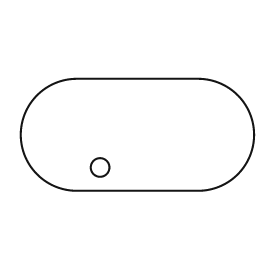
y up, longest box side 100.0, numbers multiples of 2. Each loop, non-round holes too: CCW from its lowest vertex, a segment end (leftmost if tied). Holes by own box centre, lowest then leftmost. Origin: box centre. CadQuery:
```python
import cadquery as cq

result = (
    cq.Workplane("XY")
    .moveTo(-26.0, -24.0)
    .lineTo(26.0, -24.0)
    .threePointArc((50.0, 0.0), (26.0, 24.0))
    .lineTo(-26.0, 24.0)
    .threePointArc((-50.0, 0.0), (-26.0, -24.0))
    .close()
    .moveTo(-16.0, -14.0)
    .circle(4.0)
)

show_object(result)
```